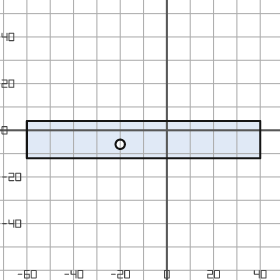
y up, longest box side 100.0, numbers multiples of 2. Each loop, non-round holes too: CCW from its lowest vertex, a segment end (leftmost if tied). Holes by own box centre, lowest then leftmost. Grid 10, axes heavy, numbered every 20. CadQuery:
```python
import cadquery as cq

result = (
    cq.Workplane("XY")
    .moveTo(-60.0, -12.0)
    .lineTo(40.0, -12.0)
    .lineTo(40.0, 4.0)
    .lineTo(-60.0, 4.0)
    .close()
    .moveTo(-20.0, -6.0)
    .circle(2.0)
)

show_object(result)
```